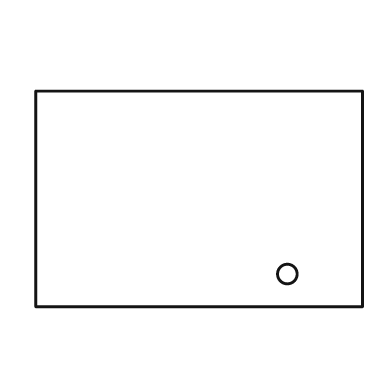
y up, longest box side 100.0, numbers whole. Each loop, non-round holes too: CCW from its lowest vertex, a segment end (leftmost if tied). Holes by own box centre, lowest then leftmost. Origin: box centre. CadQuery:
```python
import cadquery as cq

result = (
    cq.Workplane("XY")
    .moveTo(-50.0, -33.0)
    .lineTo(50.0, -33.0)
    .lineTo(50.0, 33.0)
    .lineTo(-50.0, 33.0)
    .close()
    .moveTo(27.0, -23.0)
    .circle(3.0)
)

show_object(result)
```